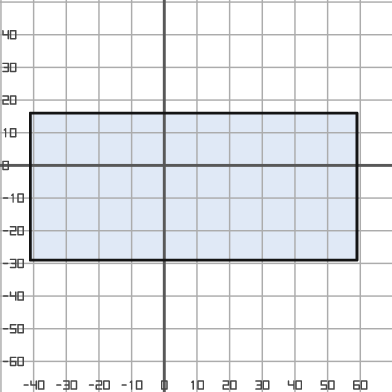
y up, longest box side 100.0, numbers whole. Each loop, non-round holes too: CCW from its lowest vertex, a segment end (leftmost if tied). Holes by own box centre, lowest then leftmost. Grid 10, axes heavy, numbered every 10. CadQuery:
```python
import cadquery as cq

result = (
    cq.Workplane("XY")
    .moveTo(-41.0, -29.0)
    .lineTo(59.0, -29.0)
    .lineTo(59.0, 16.0)
    .lineTo(-41.0, 16.0)
    .close()
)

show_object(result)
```